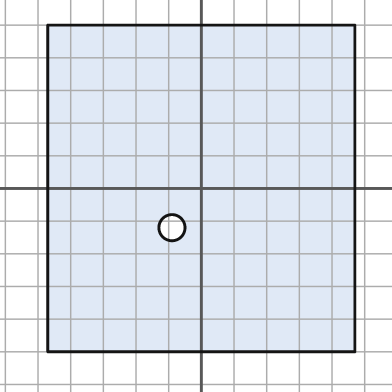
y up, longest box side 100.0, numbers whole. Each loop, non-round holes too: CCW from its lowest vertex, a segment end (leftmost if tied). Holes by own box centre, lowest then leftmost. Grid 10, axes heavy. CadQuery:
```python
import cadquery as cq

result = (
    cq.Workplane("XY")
    .moveTo(-47.0, -50.0)
    .lineTo(47.0, -50.0)
    .lineTo(47.0, 50.0)
    .lineTo(-47.0, 50.0)
    .close()
    .moveTo(-9.0, -12.0)
    .circle(4.0)
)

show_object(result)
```